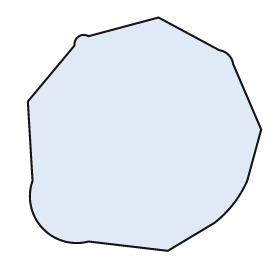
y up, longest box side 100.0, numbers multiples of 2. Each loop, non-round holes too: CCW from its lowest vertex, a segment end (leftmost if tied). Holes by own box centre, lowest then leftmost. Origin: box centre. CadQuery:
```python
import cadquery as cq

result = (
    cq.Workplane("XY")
    .moveTo(10.0, -50.0)
    .lineTo(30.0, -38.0)
    .threePointArc((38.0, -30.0), (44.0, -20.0))
    .lineTo(50.0, 2.0)
    .lineTo(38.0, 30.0)
    .threePointArc((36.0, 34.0), (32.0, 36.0))
    .lineTo(6.0, 50.0)
    .lineTo(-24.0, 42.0)
    .threePointArc((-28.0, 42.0), (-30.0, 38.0))
    .lineTo(-50.0, 14.0)
    .lineTo(-48.0, -20.0)
    .threePointArc((-44.0, -40.0), (-24.0, -46.0))
    .close()
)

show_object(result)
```